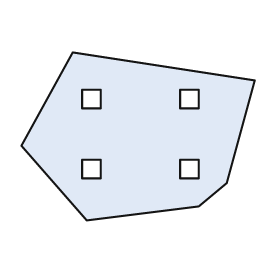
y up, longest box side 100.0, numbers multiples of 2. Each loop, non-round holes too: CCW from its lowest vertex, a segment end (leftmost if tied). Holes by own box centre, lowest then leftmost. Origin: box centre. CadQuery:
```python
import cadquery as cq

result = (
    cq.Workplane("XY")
    .moveTo(-22.0, -36.0)
    .lineTo(26.0, -30.0)
    .lineTo(38.0, -20.0)
    .lineTo(50.0, 24.0)
    .lineTo(-28.0, 36.0)
    .lineTo(-50.0, -4.0)
    .close()
    .moveTo(-24.0, -18.0)
    .lineTo(-16.0, -18.0)
    .lineTo(-16.0, -10.0)
    .lineTo(-24.0, -10.0)
    .close()
    .moveTo(18.0, -18.0)
    .lineTo(26.0, -18.0)
    .lineTo(26.0, -10.0)
    .lineTo(18.0, -10.0)
    .close()
    .moveTo(-24.0, 12.0)
    .lineTo(-16.0, 12.0)
    .lineTo(-16.0, 20.0)
    .lineTo(-24.0, 20.0)
    .close()
    .moveTo(18.0, 12.0)
    .lineTo(26.0, 12.0)
    .lineTo(26.0, 20.0)
    .lineTo(18.0, 20.0)
    .close()
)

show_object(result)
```